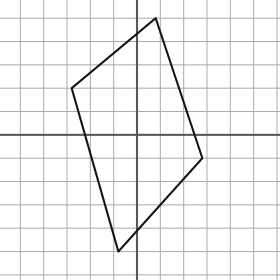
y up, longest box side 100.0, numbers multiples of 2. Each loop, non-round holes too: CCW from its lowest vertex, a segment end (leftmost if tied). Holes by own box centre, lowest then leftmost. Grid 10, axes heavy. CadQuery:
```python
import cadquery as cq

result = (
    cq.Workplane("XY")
    .moveTo(-8.0, -50.0)
    .lineTo(28.0, -10.0)
    .lineTo(8.0, 50.0)
    .lineTo(-28.0, 20.0)
    .close()
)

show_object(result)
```